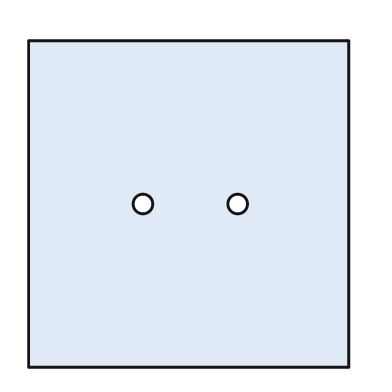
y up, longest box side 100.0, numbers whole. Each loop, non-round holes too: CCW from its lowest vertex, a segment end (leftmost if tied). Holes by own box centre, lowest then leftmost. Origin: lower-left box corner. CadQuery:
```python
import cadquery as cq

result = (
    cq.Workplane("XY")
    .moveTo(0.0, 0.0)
    .lineTo(98.0, 0.0)
    .lineTo(98.0, 100.0)
    .lineTo(0.0, 100.0)
    .close()
    .moveTo(35.0, 50.0)
    .circle(3.0)
    .moveTo(64.0, 50.0)
    .circle(3.0)
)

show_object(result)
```